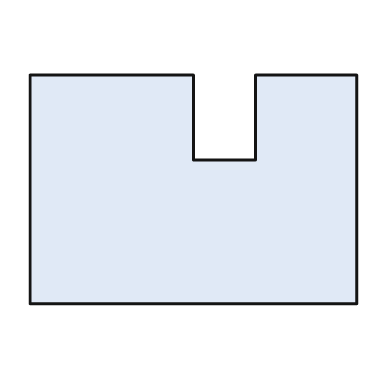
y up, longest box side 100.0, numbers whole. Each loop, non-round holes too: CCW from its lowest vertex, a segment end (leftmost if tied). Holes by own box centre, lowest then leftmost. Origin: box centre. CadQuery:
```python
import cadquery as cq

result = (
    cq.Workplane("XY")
    .moveTo(-50.0, -35.0)
    .lineTo(50.0, -35.0)
    .lineTo(50.0, 35.0)
    .lineTo(19.0, 35.0)
    .lineTo(19.0, 9.0)
    .lineTo(0.0, 9.0)
    .lineTo(0.0, 35.0)
    .lineTo(-50.0, 35.0)
    .close()
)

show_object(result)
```